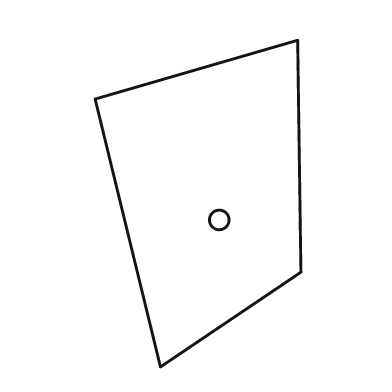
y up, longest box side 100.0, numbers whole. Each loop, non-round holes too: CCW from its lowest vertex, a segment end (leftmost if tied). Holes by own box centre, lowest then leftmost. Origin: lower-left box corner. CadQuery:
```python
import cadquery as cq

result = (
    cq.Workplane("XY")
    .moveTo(20.0, 0.0)
    .lineTo(63.0, 29.0)
    .lineTo(62.0, 100.0)
    .lineTo(0.0, 82.0)
    .close()
    .moveTo(38.0, 45.0)
    .circle(3.0)
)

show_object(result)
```